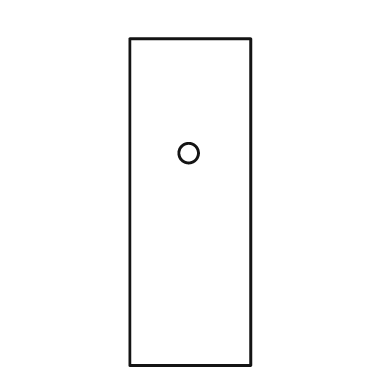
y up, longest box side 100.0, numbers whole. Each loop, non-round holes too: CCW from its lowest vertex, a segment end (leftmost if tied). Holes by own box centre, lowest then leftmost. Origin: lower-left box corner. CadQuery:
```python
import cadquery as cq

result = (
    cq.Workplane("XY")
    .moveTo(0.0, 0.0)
    .lineTo(37.0, 0.0)
    .lineTo(37.0, 100.0)
    .lineTo(0.0, 100.0)
    .close()
    .moveTo(18.0, 65.0)
    .circle(3.0)
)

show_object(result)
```